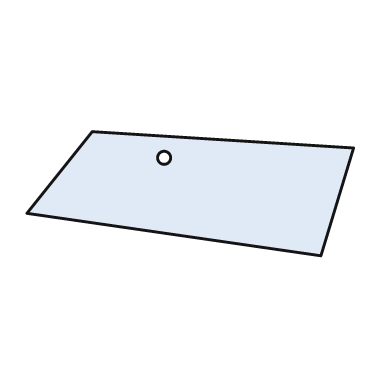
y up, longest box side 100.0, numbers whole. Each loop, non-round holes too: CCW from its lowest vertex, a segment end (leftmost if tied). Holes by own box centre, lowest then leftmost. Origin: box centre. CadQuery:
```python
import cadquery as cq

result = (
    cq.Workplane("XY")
    .moveTo(40.0, -19.0)
    .lineTo(50.0, 14.0)
    .lineTo(-30.0, 19.0)
    .lineTo(-50.0, -6.0)
    .close()
    .moveTo(-8.0, 11.0)
    .circle(2.0)
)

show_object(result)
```